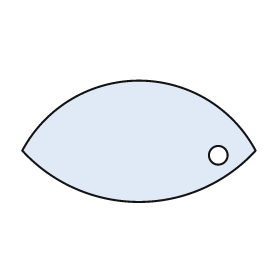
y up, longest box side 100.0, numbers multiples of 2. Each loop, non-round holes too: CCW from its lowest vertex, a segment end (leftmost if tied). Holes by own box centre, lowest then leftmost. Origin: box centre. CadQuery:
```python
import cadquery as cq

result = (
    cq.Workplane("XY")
    .moveTo(-50.0, -4.0)
    .threePointArc((0.0, -26.0), (50.0, -4.0))
    .threePointArc((0.0, 26.0), (-50.0, -4.0))
    .close()
    .moveTo(34.0, -6.0)
    .circle(4.0)
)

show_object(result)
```